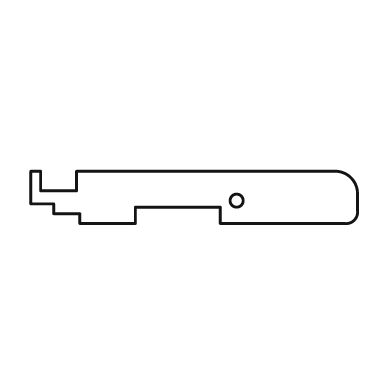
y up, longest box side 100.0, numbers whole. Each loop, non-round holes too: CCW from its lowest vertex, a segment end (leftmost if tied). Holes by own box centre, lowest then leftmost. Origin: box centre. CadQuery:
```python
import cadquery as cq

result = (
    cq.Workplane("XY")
    .moveTo(-35.0, -8.0)
    .lineTo(-18.0, -8.0)
    .lineTo(-18.0, -3.0)
    .lineTo(8.0, -3.0)
    .lineTo(8.0, -8.0)
    .lineTo(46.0, -8.0)
    .threePointArc((49.0, -7.0), (50.0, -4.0))
    .lineTo(50.0, 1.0)
    .threePointArc((48.0, 6.0), (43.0, 8.0))
    .lineTo(-36.0, 8.0)
    .lineTo(-36.0, 2.0)
    .lineTo(-47.0, 2.0)
    .lineTo(-47.0, 8.0)
    .lineTo(-50.0, 8.0)
    .lineTo(-50.0, -2.0)
    .lineTo(-43.0, -2.0)
    .lineTo(-43.0, -5.0)
    .lineTo(-35.0, -5.0)
    .close()
    .moveTo(13.0, -1.0)
    .circle(2.0)
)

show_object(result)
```